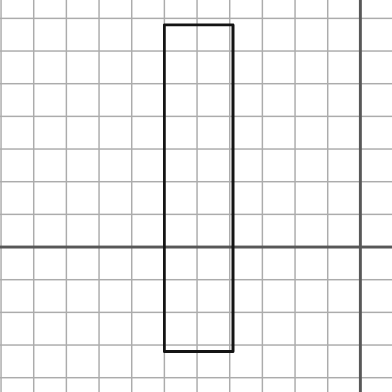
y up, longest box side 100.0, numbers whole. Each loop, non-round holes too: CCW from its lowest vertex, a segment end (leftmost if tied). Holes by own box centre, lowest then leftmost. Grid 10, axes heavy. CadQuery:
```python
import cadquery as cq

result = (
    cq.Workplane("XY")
    .moveTo(-60.0, -32.0)
    .lineTo(-39.0, -32.0)
    .lineTo(-39.0, 68.0)
    .lineTo(-60.0, 68.0)
    .close()
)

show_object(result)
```